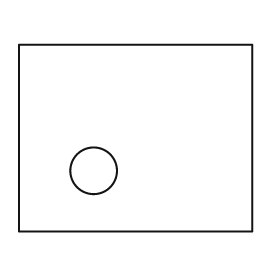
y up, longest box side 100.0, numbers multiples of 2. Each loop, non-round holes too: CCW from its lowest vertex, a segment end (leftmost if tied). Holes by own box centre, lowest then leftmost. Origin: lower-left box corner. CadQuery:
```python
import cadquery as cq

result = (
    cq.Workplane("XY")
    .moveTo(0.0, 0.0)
    .lineTo(100.0, 0.0)
    .lineTo(100.0, 80.0)
    .lineTo(0.0, 80.0)
    .close()
    .moveTo(32.0, 26.0)
    .circle(10.0)
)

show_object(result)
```